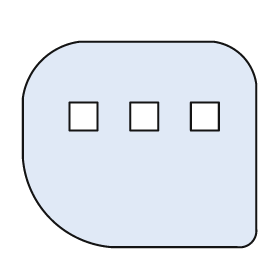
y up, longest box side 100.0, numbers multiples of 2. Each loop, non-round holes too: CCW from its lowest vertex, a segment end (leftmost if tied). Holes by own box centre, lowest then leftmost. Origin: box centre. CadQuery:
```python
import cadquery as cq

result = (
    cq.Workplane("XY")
    .moveTo(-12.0, -44.0)
    .lineTo(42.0, -44.0)
    .threePointArc((48.0, -42.0), (50.0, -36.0))
    .lineTo(50.0, 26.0)
    .threePointArc((44.0, 38.0), (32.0, 44.0))
    .lineTo(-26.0, 44.0)
    .threePointArc((-42.0, 36.0), (-50.0, 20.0))
    .lineTo(-50.0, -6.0)
    .threePointArc((-38.0, -32.0), (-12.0, -44.0))
    .close()
    .moveTo(-30.0, 6.0)
    .lineTo(-18.0, 6.0)
    .lineTo(-18.0, 18.0)
    .lineTo(-30.0, 18.0)
    .close()
    .moveTo(-4.0, 6.0)
    .lineTo(8.0, 6.0)
    .lineTo(8.0, 18.0)
    .lineTo(-4.0, 18.0)
    .close()
    .moveTo(22.0, 6.0)
    .lineTo(34.0, 6.0)
    .lineTo(34.0, 18.0)
    .lineTo(22.0, 18.0)
    .close()
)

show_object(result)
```